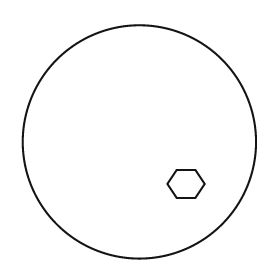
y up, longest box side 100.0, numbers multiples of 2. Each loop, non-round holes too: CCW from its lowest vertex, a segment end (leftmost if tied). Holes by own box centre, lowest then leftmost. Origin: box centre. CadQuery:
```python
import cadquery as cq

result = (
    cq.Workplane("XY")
    .moveTo(0.0, 0.0)
    .circle(50.0)
    .moveTo(16.0, -24.0)
    .lineTo(24.0, -24.0)
    .lineTo(28.0, -18.0)
    .lineTo(24.0, -12.0)
    .lineTo(16.0, -12.0)
    .lineTo(12.0, -18.0)
    .close()
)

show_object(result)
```